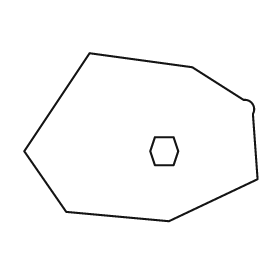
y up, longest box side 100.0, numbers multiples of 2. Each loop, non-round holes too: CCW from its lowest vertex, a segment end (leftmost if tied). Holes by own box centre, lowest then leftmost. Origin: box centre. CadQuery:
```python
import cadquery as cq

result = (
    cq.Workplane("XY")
    .moveTo(12.0, -36.0)
    .lineTo(50.0, -18.0)
    .lineTo(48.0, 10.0)
    .threePointArc((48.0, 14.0), (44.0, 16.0))
    .lineTo(22.0, 30.0)
    .lineTo(-22.0, 36.0)
    .lineTo(-50.0, -6.0)
    .lineTo(-32.0, -32.0)
    .close()
    .moveTo(6.0, -12.0)
    .lineTo(14.0, -12.0)
    .lineTo(16.0, -6.0)
    .lineTo(14.0, 0.0)
    .lineTo(6.0, 0.0)
    .lineTo(4.0, -6.0)
    .close()
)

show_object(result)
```